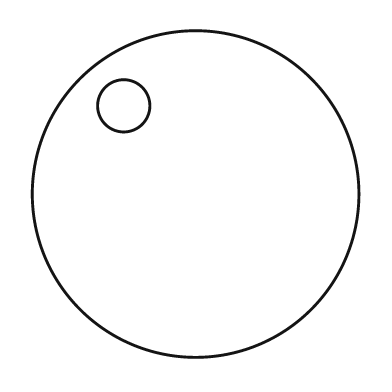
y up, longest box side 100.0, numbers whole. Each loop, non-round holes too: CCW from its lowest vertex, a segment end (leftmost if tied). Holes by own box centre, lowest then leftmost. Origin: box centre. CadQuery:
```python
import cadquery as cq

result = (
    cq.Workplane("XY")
    .moveTo(0.0, 0.0)
    .circle(50.0)
    .moveTo(-22.0, 27.0)
    .circle(8.0)
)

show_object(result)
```